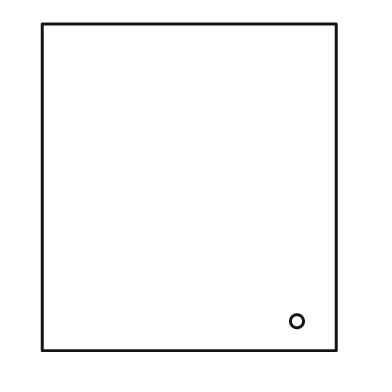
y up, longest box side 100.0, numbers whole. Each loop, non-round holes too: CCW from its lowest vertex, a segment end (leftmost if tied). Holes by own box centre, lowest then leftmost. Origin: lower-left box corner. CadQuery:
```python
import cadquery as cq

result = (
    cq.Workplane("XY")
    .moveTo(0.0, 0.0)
    .lineTo(90.0, 0.0)
    .lineTo(90.0, 100.0)
    .lineTo(0.0, 100.0)
    .close()
    .moveTo(78.0, 9.0)
    .circle(2.0)
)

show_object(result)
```